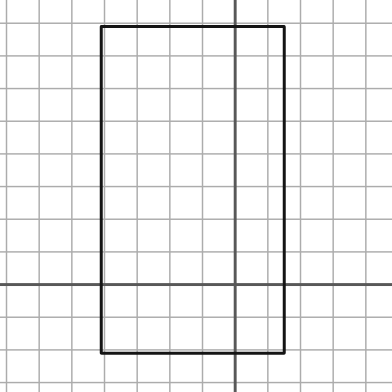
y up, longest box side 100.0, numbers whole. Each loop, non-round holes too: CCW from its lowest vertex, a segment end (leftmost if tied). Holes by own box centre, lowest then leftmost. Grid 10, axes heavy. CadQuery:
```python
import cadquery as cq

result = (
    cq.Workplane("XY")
    .moveTo(-41.0, -21.0)
    .lineTo(15.0, -21.0)
    .lineTo(15.0, 79.0)
    .lineTo(-41.0, 79.0)
    .close()
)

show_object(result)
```